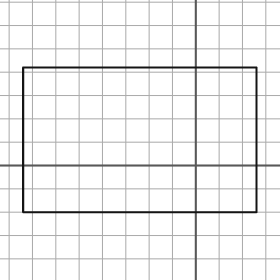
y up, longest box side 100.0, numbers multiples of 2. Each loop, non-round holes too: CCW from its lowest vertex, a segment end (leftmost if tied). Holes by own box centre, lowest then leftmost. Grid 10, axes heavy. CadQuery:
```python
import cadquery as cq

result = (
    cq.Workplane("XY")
    .moveTo(-74.0, -20.0)
    .lineTo(26.0, -20.0)
    .lineTo(26.0, 42.0)
    .lineTo(-74.0, 42.0)
    .close()
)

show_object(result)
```